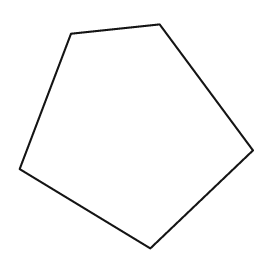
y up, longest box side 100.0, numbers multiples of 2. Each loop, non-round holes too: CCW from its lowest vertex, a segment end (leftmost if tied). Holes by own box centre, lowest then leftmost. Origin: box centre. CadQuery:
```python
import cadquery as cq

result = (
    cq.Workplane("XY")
    .moveTo(6.0, -48.0)
    .lineTo(50.0, -6.0)
    .lineTo(10.0, 48.0)
    .lineTo(-28.0, 44.0)
    .lineTo(-50.0, -14.0)
    .close()
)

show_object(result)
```